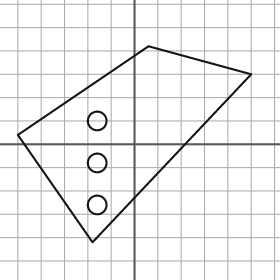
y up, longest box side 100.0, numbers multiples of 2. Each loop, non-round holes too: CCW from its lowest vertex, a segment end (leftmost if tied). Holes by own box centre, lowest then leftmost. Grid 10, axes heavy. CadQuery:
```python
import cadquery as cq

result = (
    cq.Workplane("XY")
    .moveTo(-18.0, -42.0)
    .lineTo(50.0, 30.0)
    .lineTo(6.0, 42.0)
    .lineTo(-50.0, 4.0)
    .close()
    .moveTo(-16.0, -26.0)
    .circle(4.0)
    .moveTo(-16.0, -8.0)
    .circle(4.0)
    .moveTo(-16.0, 10.0)
    .circle(4.0)
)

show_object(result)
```